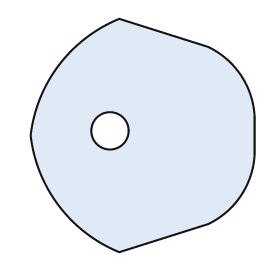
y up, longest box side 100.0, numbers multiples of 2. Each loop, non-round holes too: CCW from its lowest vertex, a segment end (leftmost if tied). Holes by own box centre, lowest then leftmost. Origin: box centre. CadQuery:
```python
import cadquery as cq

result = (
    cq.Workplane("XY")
    .moveTo(-10.0, -50.0)
    .lineTo(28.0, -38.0)
    .threePointArc((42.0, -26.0), (48.0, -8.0))
    .lineTo(48.0, 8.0)
    .threePointArc((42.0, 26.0), (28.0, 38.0))
    .lineTo(-10.0, 50.0)
    .threePointArc((-36.0, 30.0), (-48.0, 0.0))
    .threePointArc((-36.0, -30.0), (-10.0, -50.0))
    .close()
    .moveTo(-14.0, 2.0)
    .circle(8.0)
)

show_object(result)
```